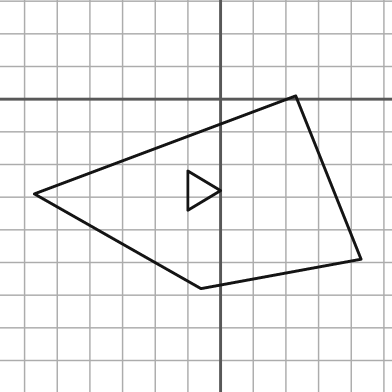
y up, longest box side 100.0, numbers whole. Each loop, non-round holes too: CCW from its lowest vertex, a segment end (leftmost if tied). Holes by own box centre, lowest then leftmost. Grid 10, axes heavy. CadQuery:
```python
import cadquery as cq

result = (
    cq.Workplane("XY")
    .moveTo(-6.0, -58.0)
    .lineTo(43.0, -49.0)
    .lineTo(23.0, 1.0)
    .lineTo(-57.0, -29.0)
    .close()
    .moveTo(-10.0, -34.0)
    .lineTo(0.0, -28.0)
    .lineTo(-10.0, -22.0)
    .close()
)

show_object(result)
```